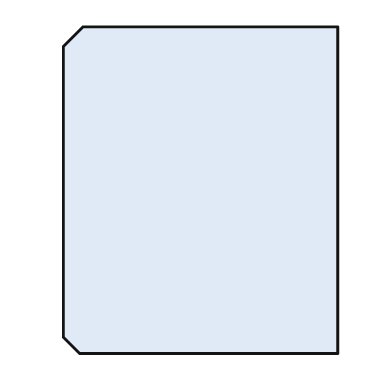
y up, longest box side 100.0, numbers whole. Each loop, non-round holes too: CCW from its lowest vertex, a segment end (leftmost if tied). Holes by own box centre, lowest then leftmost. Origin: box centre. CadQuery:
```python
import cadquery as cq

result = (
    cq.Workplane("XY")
    .moveTo(-37.0, -50.0)
    .lineTo(42.0, -50.0)
    .lineTo(42.0, 50.0)
    .lineTo(-36.0, 50.0)
    .lineTo(-42.0, 44.0)
    .lineTo(-42.0, -45.0)
    .close()
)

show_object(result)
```